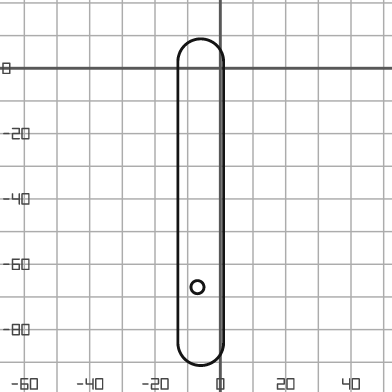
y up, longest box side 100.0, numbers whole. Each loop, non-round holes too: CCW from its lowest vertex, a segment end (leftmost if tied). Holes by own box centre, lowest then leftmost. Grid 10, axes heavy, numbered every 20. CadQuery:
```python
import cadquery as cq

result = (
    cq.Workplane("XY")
    .moveTo(-13.0, -84.0)
    .threePointArc((-6.0, -91.0), (1.0, -84.0))
    .lineTo(1.0, 2.0)
    .threePointArc((-6.0, 9.0), (-13.0, 2.0))
    .close()
    .moveTo(-7.0, -67.0)
    .circle(2.0)
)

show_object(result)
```